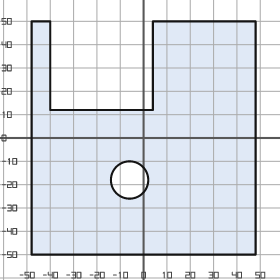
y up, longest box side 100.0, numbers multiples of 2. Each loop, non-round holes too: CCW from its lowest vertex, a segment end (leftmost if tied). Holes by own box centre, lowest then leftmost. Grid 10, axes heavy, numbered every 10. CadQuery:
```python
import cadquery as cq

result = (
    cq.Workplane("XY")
    .moveTo(-48.0, -50.0)
    .lineTo(48.0, -50.0)
    .lineTo(48.0, 50.0)
    .lineTo(4.0, 50.0)
    .lineTo(4.0, 12.0)
    .lineTo(-40.0, 12.0)
    .lineTo(-40.0, 50.0)
    .lineTo(-48.0, 50.0)
    .close()
    .moveTo(-6.0, -18.0)
    .circle(8.0)
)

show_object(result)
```